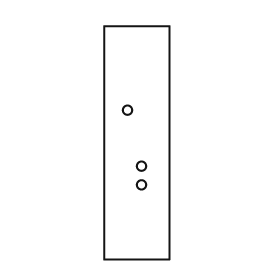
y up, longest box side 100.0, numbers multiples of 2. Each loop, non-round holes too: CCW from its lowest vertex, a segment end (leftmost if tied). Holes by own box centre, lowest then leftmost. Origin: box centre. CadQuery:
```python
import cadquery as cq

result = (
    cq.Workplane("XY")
    .moveTo(-14.0, -50.0)
    .lineTo(14.0, -50.0)
    .lineTo(14.0, 50.0)
    .lineTo(-14.0, 50.0)
    .close()
    .moveTo(2.0, -18.0)
    .circle(2.0)
    .moveTo(2.0, -10.0)
    .circle(2.0)
    .moveTo(-4.0, 14.0)
    .circle(2.0)
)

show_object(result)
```